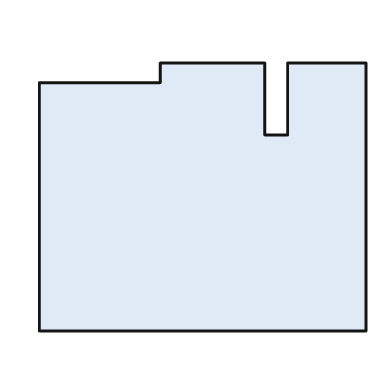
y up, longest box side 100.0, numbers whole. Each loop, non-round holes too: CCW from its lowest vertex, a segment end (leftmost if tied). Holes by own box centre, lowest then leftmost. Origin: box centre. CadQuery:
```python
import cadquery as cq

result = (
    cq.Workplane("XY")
    .moveTo(-50.0, -41.0)
    .lineTo(50.0, -41.0)
    .lineTo(50.0, 41.0)
    .lineTo(26.0, 41.0)
    .lineTo(26.0, 19.0)
    .lineTo(19.0, 19.0)
    .lineTo(19.0, 41.0)
    .lineTo(-13.0, 41.0)
    .lineTo(-13.0, 35.0)
    .lineTo(-50.0, 35.0)
    .close()
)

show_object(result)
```